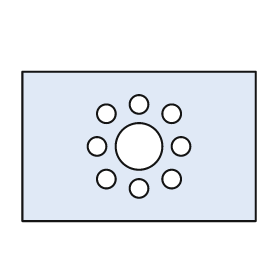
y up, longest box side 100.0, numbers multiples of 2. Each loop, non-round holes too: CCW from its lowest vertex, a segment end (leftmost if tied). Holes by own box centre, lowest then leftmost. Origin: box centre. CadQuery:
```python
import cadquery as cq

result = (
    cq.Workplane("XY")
    .moveTo(-50.0, -32.0)
    .lineTo(50.0, -32.0)
    .lineTo(50.0, 32.0)
    .lineTo(-50.0, 32.0)
    .close()
    .moveTo(0.0, -18.0)
    .circle(4.0)
    .moveTo(-14.0, -14.0)
    .circle(4.0)
    .moveTo(14.0, -14.0)
    .circle(4.0)
    .moveTo(-18.0, 0.0)
    .circle(4.0)
    .moveTo(0.0, 0.0)
    .circle(10.0)
    .moveTo(18.0, 0.0)
    .circle(4.0)
    .moveTo(-14.0, 14.0)
    .circle(4.0)
    .moveTo(14.0, 14.0)
    .circle(4.0)
    .moveTo(0.0, 18.0)
    .circle(4.0)
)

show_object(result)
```